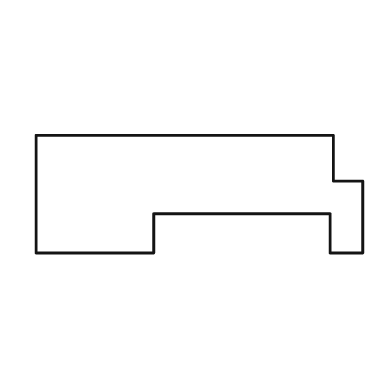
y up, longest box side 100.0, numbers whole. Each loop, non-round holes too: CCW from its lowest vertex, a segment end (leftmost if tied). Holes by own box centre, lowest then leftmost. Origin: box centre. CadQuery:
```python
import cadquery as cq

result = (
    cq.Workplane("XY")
    .moveTo(-50.0, -18.0)
    .lineTo(-14.0, -18.0)
    .lineTo(-14.0, -6.0)
    .lineTo(40.0, -6.0)
    .lineTo(40.0, -18.0)
    .lineTo(50.0, -18.0)
    .lineTo(50.0, 4.0)
    .lineTo(41.0, 4.0)
    .lineTo(41.0, 18.0)
    .lineTo(-50.0, 18.0)
    .close()
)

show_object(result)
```